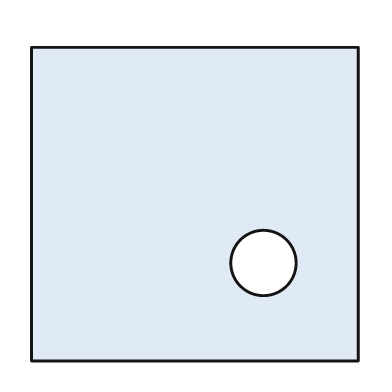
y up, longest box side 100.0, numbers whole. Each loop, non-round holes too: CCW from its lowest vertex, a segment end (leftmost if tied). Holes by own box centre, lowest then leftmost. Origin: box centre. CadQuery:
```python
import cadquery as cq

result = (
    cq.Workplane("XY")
    .moveTo(-50.0, -48.0)
    .lineTo(50.0, -48.0)
    .lineTo(50.0, 48.0)
    .lineTo(-50.0, 48.0)
    .close()
    .moveTo(21.0, -18.0)
    .circle(10.0)
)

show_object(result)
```